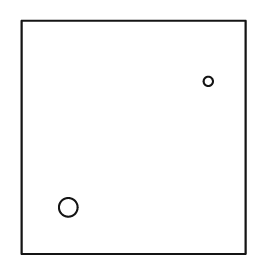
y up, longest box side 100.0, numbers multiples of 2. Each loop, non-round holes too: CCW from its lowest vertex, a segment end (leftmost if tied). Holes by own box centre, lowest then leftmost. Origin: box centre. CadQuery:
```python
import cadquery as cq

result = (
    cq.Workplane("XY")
    .moveTo(-48.0, -50.0)
    .lineTo(48.0, -50.0)
    .lineTo(48.0, 50.0)
    .lineTo(-48.0, 50.0)
    .close()
    .moveTo(-28.0, -30.0)
    .circle(4.0)
    .moveTo(32.0, 24.0)
    .circle(2.0)
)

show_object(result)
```